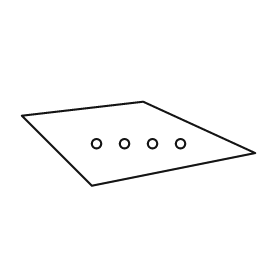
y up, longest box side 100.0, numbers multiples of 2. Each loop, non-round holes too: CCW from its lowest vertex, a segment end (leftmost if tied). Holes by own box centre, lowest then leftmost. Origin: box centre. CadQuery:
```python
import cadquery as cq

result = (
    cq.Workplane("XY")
    .moveTo(-20.0, -18.0)
    .lineTo(50.0, -4.0)
    .lineTo(2.0, 18.0)
    .lineTo(-50.0, 12.0)
    .close()
    .moveTo(-18.0, 0.0)
    .circle(2.0)
    .moveTo(-6.0, 0.0)
    .circle(2.0)
    .moveTo(6.0, 0.0)
    .circle(2.0)
    .moveTo(18.0, 0.0)
    .circle(2.0)
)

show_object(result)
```